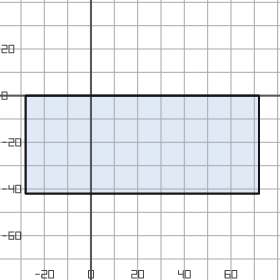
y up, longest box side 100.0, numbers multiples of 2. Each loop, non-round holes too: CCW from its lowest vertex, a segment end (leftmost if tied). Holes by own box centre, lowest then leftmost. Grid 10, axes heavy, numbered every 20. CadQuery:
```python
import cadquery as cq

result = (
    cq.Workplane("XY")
    .moveTo(-28.0, -42.0)
    .lineTo(72.0, -42.0)
    .lineTo(72.0, 0.0)
    .lineTo(-28.0, 0.0)
    .close()
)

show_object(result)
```